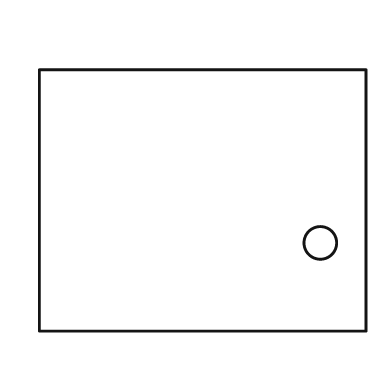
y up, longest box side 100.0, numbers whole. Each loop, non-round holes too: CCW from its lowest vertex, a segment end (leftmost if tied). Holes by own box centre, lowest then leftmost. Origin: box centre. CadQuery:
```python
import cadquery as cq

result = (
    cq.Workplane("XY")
    .moveTo(-50.0, -40.0)
    .lineTo(50.0, -40.0)
    .lineTo(50.0, 40.0)
    .lineTo(-50.0, 40.0)
    .close()
    .moveTo(36.0, -13.0)
    .circle(5.0)
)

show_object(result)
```